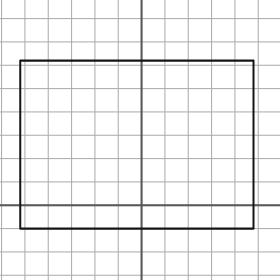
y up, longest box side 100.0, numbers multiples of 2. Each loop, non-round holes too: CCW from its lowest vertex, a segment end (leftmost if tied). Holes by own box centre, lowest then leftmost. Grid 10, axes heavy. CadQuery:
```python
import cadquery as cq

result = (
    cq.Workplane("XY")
    .moveTo(-52.0, -10.0)
    .lineTo(48.0, -10.0)
    .lineTo(48.0, 62.0)
    .lineTo(-52.0, 62.0)
    .close()
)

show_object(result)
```